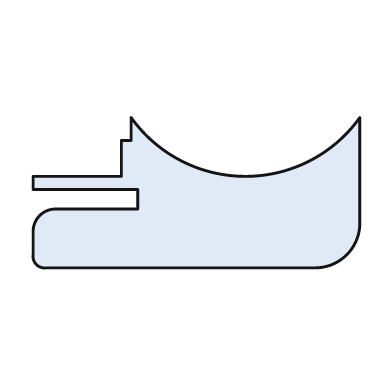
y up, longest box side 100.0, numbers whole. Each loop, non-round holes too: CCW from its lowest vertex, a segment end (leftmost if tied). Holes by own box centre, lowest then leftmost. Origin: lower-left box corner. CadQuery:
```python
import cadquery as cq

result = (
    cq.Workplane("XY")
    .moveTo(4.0, 0.0)
    .lineTo(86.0, 0.0)
    .threePointArc((96.0, 4.0), (100.0, 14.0))
    .lineTo(100.0, 46.0)
    .threePointArc((65.0, 28.0), (30.0, 46.0))
    .lineTo(30.0, 39.0)
    .lineTo(27.0, 39.0)
    .lineTo(27.0, 28.0)
    .lineTo(0.0, 28.0)
    .lineTo(0.0, 24.0)
    .lineTo(32.0, 24.0)
    .lineTo(32.0, 18.0)
    .lineTo(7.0, 18.0)
    .threePointArc((2.0, 16.0), (0.0, 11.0))
    .lineTo(0.0, 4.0)
    .threePointArc((1.0, 1.0), (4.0, 0.0))
    .close()
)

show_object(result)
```